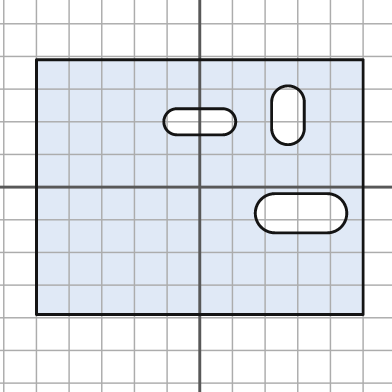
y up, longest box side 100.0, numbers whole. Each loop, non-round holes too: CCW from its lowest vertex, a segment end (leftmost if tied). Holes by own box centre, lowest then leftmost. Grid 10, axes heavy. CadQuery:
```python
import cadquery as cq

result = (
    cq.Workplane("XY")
    .moveTo(-50.0, -39.0)
    .lineTo(50.0, -39.0)
    .lineTo(50.0, 39.0)
    .lineTo(-50.0, 39.0)
    .close()
    .moveTo(23.0, -14.0)
    .lineTo(39.0, -14.0)
    .threePointArc((45.0, -8.0), (39.0, -2.0))
    .lineTo(23.0, -2.0)
    .threePointArc((17.0, -8.0), (23.0, -14.0))
    .close()
    .moveTo(-7.0, 16.0)
    .lineTo(7.0, 16.0)
    .threePointArc((11.0, 20.0), (7.0, 24.0))
    .lineTo(-7.0, 24.0)
    .threePointArc((-11.0, 20.0), (-7.0, 16.0))
    .close()
    .moveTo(22.0, 18.0)
    .threePointArc((27.0, 13.0), (32.0, 18.0))
    .lineTo(32.0, 26.0)
    .threePointArc((27.0, 31.0), (22.0, 26.0))
    .close()
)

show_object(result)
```